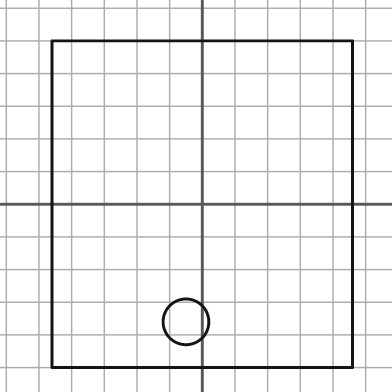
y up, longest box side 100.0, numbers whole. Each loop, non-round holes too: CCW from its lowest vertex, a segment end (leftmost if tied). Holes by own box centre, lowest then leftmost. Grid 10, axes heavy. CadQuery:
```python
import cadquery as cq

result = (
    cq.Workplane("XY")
    .moveTo(-46.0, -50.0)
    .lineTo(46.0, -50.0)
    .lineTo(46.0, 50.0)
    .lineTo(-46.0, 50.0)
    .close()
    .moveTo(-5.0, -36.0)
    .circle(7.0)
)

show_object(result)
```